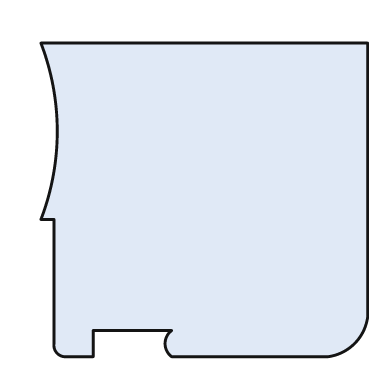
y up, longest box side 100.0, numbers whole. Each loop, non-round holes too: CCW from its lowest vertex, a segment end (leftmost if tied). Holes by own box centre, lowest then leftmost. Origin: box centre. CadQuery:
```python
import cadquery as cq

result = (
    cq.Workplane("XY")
    .moveTo(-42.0, -48.0)
    .lineTo(-34.0, -48.0)
    .lineTo(-34.0, -40.0)
    .lineTo(-10.0, -40.0)
    .threePointArc((-12.0, -44.0), (-10.0, -48.0))
    .lineTo(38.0, -48.0)
    .threePointArc((46.0, -44.0), (50.0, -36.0))
    .lineTo(50.0, 48.0)
    .lineTo(-50.0, 48.0)
    .threePointArc((-45.0, 21.0), (-50.0, -6.0))
    .lineTo(-46.0, -6.0)
    .lineTo(-46.0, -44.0)
    .threePointArc((-45.0, -47.0), (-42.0, -48.0))
    .close()
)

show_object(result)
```